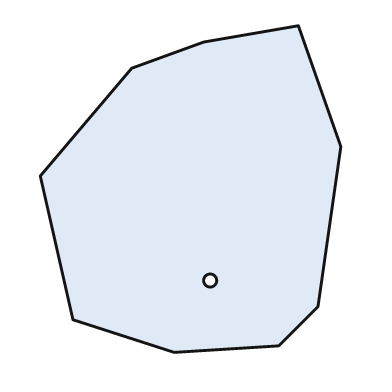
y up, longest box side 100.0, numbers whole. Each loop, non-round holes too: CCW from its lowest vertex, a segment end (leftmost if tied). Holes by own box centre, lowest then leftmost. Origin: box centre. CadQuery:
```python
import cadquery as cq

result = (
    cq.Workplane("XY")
    .moveTo(-5.0, -50.0)
    .lineTo(27.0, -48.0)
    .lineTo(39.0, -36.0)
    .lineTo(46.0, 13.0)
    .lineTo(33.0, 50.0)
    .lineTo(4.0, 45.0)
    .lineTo(-18.0, 37.0)
    .lineTo(-46.0, 4.0)
    .lineTo(-36.0, -40.0)
    .close()
    .moveTo(6.0, -28.0)
    .circle(2.0)
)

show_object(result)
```